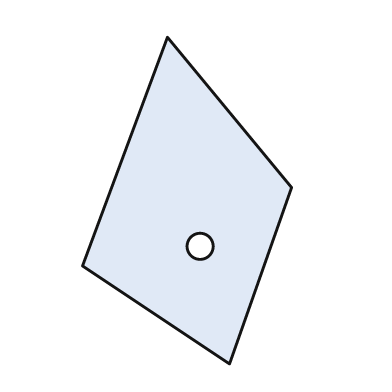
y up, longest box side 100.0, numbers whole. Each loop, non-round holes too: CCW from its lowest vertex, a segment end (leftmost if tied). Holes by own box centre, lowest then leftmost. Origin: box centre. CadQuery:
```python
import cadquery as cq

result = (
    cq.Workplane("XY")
    .moveTo(13.0, -50.0)
    .lineTo(32.0, 4.0)
    .lineTo(-6.0, 50.0)
    .lineTo(-32.0, -20.0)
    .close()
    .moveTo(4.0, -14.0)
    .circle(4.0)
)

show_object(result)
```